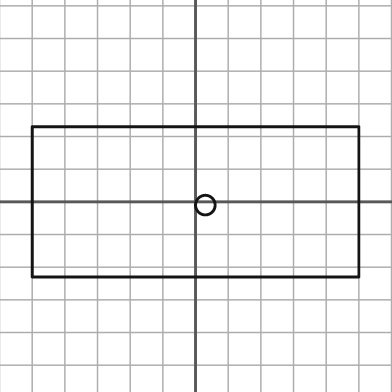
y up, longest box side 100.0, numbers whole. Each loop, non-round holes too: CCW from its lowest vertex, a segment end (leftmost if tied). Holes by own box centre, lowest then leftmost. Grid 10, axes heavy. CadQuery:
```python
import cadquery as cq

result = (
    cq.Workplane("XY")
    .moveTo(-50.0, -23.0)
    .lineTo(50.0, -23.0)
    .lineTo(50.0, 23.0)
    .lineTo(-50.0, 23.0)
    .close()
    .moveTo(3.0, -1.0)
    .circle(3.0)
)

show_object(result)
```